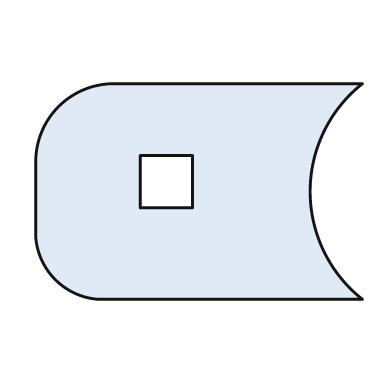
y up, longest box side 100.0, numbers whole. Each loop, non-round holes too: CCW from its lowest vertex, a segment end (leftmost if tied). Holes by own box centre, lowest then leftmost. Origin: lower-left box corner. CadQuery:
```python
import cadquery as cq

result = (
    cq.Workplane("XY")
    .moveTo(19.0, 0.0)
    .lineTo(100.0, 0.0)
    .threePointArc((84.0, 33.0), (100.0, 66.0))
    .lineTo(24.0, 66.0)
    .threePointArc((7.0, 59.0), (0.0, 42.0))
    .lineTo(0.0, 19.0)
    .threePointArc((6.0, 6.0), (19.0, 0.0))
    .close()
    .moveTo(32.0, 28.0)
    .lineTo(48.0, 28.0)
    .lineTo(48.0, 44.0)
    .lineTo(32.0, 44.0)
    .close()
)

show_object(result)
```